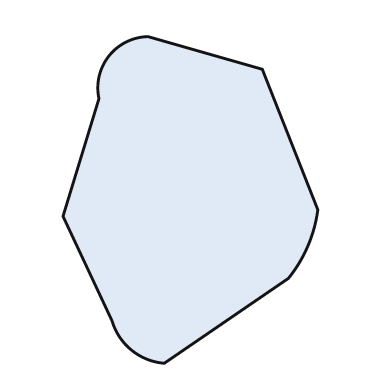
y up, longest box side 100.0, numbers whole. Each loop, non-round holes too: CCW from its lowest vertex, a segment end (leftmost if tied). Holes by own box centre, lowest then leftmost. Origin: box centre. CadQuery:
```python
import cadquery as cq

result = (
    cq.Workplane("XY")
    .moveTo(-8.0, -50.0)
    .lineTo(30.0, -24.0)
    .threePointArc((36.0, -14.0), (39.0, -3.0))
    .lineTo(22.0, 40.0)
    .lineTo(-13.0, 50.0)
    .threePointArc((-25.0, 44.0), (-28.0, 31.0))
    .lineTo(-39.0, -5.0)
    .lineTo(-24.0, -37.0)
    .threePointArc((-18.0, -46.0), (-8.0, -50.0))
    .close()
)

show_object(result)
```